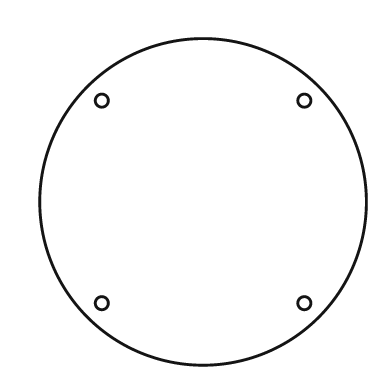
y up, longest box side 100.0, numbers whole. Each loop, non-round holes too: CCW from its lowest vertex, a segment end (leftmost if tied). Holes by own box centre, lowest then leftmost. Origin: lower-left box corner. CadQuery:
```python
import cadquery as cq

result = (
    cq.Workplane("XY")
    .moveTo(50.0, 50.0)
    .circle(50.0)
    .moveTo(19.0, 19.0)
    .circle(2.0)
    .moveTo(81.0, 19.0)
    .circle(2.0)
    .moveTo(19.0, 81.0)
    .circle(2.0)
    .moveTo(81.0, 81.0)
    .circle(2.0)
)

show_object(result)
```